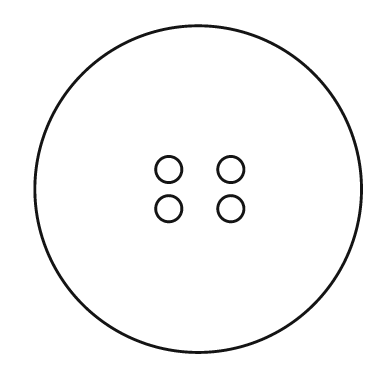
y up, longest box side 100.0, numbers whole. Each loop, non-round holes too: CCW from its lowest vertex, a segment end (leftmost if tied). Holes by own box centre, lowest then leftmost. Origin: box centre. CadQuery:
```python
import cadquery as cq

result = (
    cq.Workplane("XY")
    .moveTo(0.0, 0.0)
    .circle(50.0)
    .moveTo(-9.0, -6.0)
    .circle(4.0)
    .moveTo(10.0, -6.0)
    .circle(4.0)
    .moveTo(-9.0, 6.0)
    .circle(4.0)
    .moveTo(10.0, 6.0)
    .circle(4.0)
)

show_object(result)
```